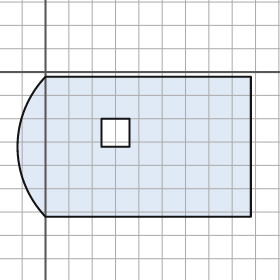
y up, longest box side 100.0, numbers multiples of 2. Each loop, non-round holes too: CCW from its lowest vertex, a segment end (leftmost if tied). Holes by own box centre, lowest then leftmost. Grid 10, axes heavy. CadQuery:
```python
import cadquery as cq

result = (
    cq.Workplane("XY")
    .moveTo(0.0, -62.0)
    .lineTo(88.0, -62.0)
    .lineTo(88.0, -2.0)
    .lineTo(0.0, -2.0)
    .threePointArc((-12.0, -32.0), (0.0, -62.0))
    .close()
    .moveTo(24.0, -32.0)
    .lineTo(36.0, -32.0)
    .lineTo(36.0, -20.0)
    .lineTo(24.0, -20.0)
    .close()
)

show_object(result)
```